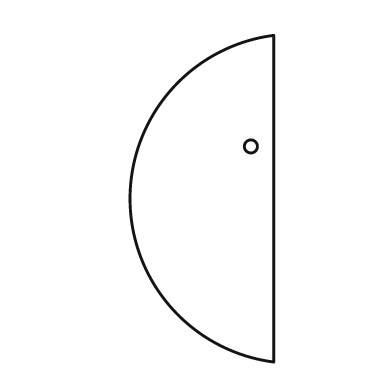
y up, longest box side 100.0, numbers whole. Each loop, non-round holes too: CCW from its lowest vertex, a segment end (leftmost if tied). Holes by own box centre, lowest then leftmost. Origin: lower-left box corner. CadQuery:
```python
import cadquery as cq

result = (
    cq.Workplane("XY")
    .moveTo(44.0, 0.0)
    .lineTo(44.0, 100.0)
    .threePointArc((0.0, 50.0), (44.0, 0.0))
    .close()
    .moveTo(37.0, 66.0)
    .circle(2.0)
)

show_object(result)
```